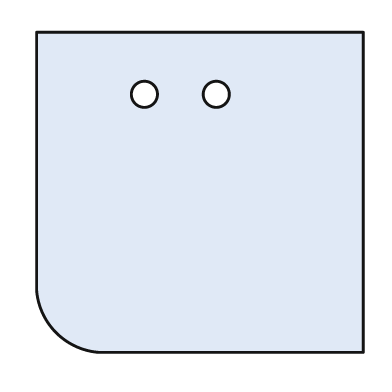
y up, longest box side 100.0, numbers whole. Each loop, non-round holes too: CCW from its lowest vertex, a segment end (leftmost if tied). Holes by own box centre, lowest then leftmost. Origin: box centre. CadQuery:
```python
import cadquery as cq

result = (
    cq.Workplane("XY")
    .moveTo(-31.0, -49.0)
    .lineTo(50.0, -49.0)
    .lineTo(50.0, 49.0)
    .lineTo(-50.0, 49.0)
    .lineTo(-50.0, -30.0)
    .threePointArc((-44.0, -43.0), (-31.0, -49.0))
    .close()
    .moveTo(-17.0, 30.0)
    .circle(4.0)
    .moveTo(5.0, 30.0)
    .circle(4.0)
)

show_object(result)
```